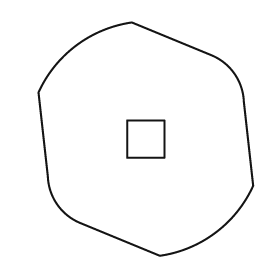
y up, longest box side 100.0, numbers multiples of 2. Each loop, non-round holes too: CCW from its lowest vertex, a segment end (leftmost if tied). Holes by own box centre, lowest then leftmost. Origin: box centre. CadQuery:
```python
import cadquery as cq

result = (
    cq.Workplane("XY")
    .moveTo(6.0, -50.0)
    .threePointArc((30.0, -40.0), (46.0, -20.0))
    .lineTo(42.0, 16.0)
    .threePointArc((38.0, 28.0), (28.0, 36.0))
    .lineTo(-6.0, 50.0)
    .threePointArc((-30.0, 40.0), (-46.0, 20.0))
    .lineTo(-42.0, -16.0)
    .threePointArc((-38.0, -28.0), (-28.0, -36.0))
    .close()
    .moveTo(-8.0, -8.0)
    .lineTo(8.0, -8.0)
    .lineTo(8.0, 8.0)
    .lineTo(-8.0, 8.0)
    .close()
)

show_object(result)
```